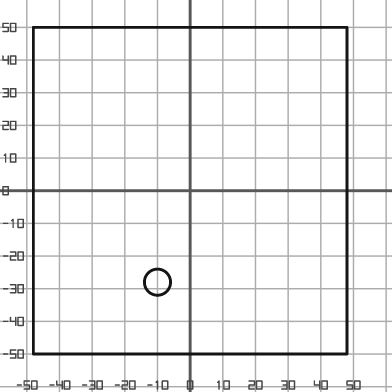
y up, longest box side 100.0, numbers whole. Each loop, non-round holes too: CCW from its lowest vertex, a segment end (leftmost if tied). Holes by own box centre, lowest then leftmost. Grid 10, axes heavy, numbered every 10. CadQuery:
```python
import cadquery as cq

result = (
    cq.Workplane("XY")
    .moveTo(-48.0, -50.0)
    .lineTo(48.0, -50.0)
    .lineTo(48.0, 50.0)
    .lineTo(-48.0, 50.0)
    .close()
    .moveTo(-10.0, -28.0)
    .circle(4.0)
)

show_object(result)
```